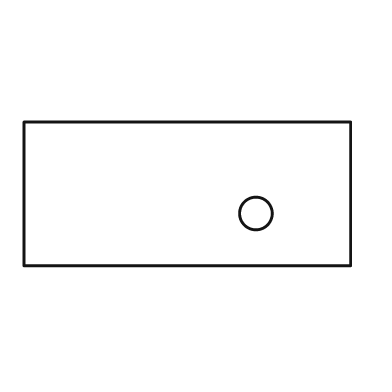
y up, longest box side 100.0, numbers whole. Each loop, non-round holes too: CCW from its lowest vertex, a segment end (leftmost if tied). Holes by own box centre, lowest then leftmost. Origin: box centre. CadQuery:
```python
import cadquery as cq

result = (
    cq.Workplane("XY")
    .moveTo(-50.0, -22.0)
    .lineTo(50.0, -22.0)
    .lineTo(50.0, 22.0)
    .lineTo(-50.0, 22.0)
    .close()
    .moveTo(21.0, -6.0)
    .circle(5.0)
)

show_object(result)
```